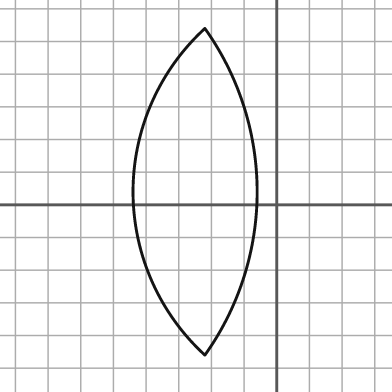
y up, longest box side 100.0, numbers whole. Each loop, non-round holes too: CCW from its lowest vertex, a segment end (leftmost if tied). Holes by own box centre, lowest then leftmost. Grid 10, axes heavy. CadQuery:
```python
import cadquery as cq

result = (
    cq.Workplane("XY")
    .moveTo(-22.0, -46.0)
    .threePointArc((-6.0, 4.0), (-22.0, 54.0))
    .threePointArc((-44.0, 4.0), (-22.0, -46.0))
    .close()
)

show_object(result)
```